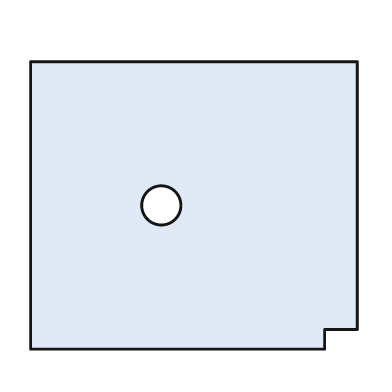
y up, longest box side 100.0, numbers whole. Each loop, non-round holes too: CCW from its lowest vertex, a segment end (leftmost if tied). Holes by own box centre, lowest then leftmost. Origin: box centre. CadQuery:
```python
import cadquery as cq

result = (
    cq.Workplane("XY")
    .moveTo(-50.0, -44.0)
    .lineTo(40.0, -44.0)
    .lineTo(40.0, -38.0)
    .lineTo(50.0, -38.0)
    .lineTo(50.0, 44.0)
    .lineTo(-50.0, 44.0)
    .close()
    .moveTo(-10.0, 0.0)
    .circle(6.0)
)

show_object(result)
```